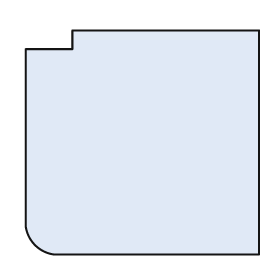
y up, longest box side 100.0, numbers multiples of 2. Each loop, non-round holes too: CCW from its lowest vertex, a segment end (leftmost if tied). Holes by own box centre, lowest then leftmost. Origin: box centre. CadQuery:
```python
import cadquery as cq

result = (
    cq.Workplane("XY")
    .moveTo(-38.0, -48.0)
    .lineTo(50.0, -48.0)
    .lineTo(50.0, 48.0)
    .lineTo(-30.0, 48.0)
    .lineTo(-30.0, 40.0)
    .lineTo(-50.0, 40.0)
    .lineTo(-50.0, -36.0)
    .threePointArc((-46.0, -44.0), (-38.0, -48.0))
    .close()
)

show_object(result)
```